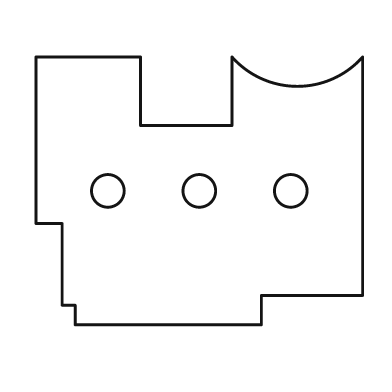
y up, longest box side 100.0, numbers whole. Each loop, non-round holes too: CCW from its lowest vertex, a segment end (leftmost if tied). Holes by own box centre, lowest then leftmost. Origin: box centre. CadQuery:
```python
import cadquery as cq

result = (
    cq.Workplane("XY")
    .moveTo(-38.0, -41.0)
    .lineTo(19.0, -41.0)
    .lineTo(19.0, -32.0)
    .lineTo(50.0, -32.0)
    .lineTo(50.0, 41.0)
    .threePointArc((30.0, 32.0), (10.0, 41.0))
    .lineTo(10.0, 20.0)
    .lineTo(-18.0, 20.0)
    .lineTo(-18.0, 41.0)
    .lineTo(-50.0, 41.0)
    .lineTo(-50.0, -10.0)
    .lineTo(-42.0, -10.0)
    .lineTo(-42.0, -35.0)
    .lineTo(-38.0, -35.0)
    .close()
    .moveTo(-28.0, 0.0)
    .circle(5.0)
    .moveTo(0.0, 0.0)
    .circle(5.0)
    .moveTo(28.0, 0.0)
    .circle(5.0)
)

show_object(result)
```